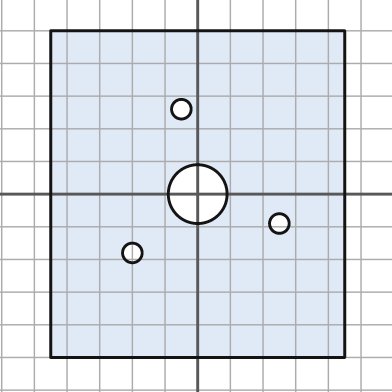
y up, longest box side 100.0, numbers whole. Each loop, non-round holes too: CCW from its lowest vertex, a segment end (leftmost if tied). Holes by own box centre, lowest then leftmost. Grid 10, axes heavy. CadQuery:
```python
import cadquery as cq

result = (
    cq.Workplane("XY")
    .moveTo(-45.0, -50.0)
    .lineTo(45.0, -50.0)
    .lineTo(45.0, 50.0)
    .lineTo(-45.0, 50.0)
    .close()
    .moveTo(-20.0, -18.0)
    .circle(3.0)
    .moveTo(25.0, -9.0)
    .circle(3.0)
    .moveTo(0.0, 0.0)
    .circle(9.0)
    .moveTo(-5.0, 26.0)
    .circle(3.0)
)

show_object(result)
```